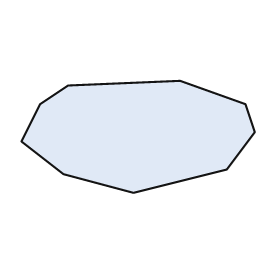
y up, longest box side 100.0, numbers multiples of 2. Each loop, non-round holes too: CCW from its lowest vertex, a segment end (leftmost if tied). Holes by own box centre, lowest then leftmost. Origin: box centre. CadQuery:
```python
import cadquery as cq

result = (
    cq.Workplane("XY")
    .moveTo(-2.0, -24.0)
    .lineTo(38.0, -14.0)
    .lineTo(50.0, 2.0)
    .lineTo(46.0, 14.0)
    .lineTo(18.0, 24.0)
    .lineTo(-30.0, 22.0)
    .lineTo(-42.0, 14.0)
    .lineTo(-50.0, -2.0)
    .lineTo(-32.0, -16.0)
    .close()
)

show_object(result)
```